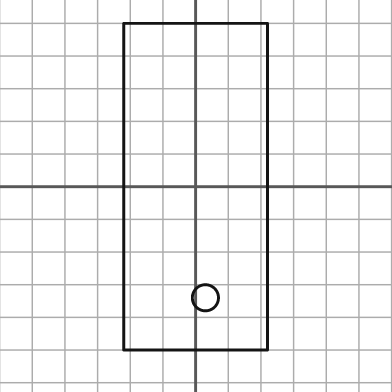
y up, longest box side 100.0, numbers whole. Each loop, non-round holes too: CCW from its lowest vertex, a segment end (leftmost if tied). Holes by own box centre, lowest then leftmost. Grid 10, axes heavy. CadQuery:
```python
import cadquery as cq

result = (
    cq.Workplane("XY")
    .moveTo(-22.0, -50.0)
    .lineTo(22.0, -50.0)
    .lineTo(22.0, 50.0)
    .lineTo(-22.0, 50.0)
    .close()
    .moveTo(3.0, -34.0)
    .circle(4.0)
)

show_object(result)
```